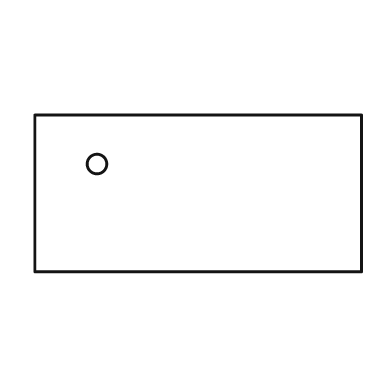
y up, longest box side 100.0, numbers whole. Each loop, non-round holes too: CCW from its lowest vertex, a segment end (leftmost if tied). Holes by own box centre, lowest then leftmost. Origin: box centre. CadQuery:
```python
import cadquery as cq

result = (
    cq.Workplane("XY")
    .moveTo(-50.0, -24.0)
    .lineTo(50.0, -24.0)
    .lineTo(50.0, 24.0)
    .lineTo(-50.0, 24.0)
    .close()
    .moveTo(-31.0, 9.0)
    .circle(3.0)
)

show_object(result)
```